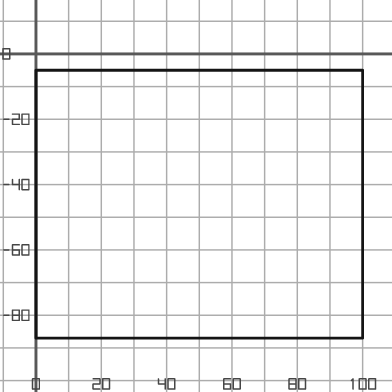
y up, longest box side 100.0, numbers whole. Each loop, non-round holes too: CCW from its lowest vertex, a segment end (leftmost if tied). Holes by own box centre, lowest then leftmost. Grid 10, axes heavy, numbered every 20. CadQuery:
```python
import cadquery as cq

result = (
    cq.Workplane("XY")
    .moveTo(0.0, -87.0)
    .lineTo(100.0, -87.0)
    .lineTo(100.0, -5.0)
    .lineTo(0.0, -5.0)
    .close()
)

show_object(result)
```